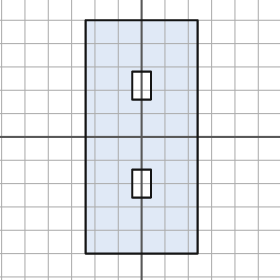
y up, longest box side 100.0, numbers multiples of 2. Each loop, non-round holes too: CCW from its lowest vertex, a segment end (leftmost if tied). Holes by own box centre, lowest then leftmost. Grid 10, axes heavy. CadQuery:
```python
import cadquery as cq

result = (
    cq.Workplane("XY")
    .moveTo(-24.0, -50.0)
    .lineTo(24.0, -50.0)
    .lineTo(24.0, 50.0)
    .lineTo(-24.0, 50.0)
    .close()
    .moveTo(-4.0, -26.0)
    .lineTo(4.0, -26.0)
    .lineTo(4.0, -14.0)
    .lineTo(-4.0, -14.0)
    .close()
    .moveTo(-4.0, 16.0)
    .lineTo(4.0, 16.0)
    .lineTo(4.0, 28.0)
    .lineTo(-4.0, 28.0)
    .close()
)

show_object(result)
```